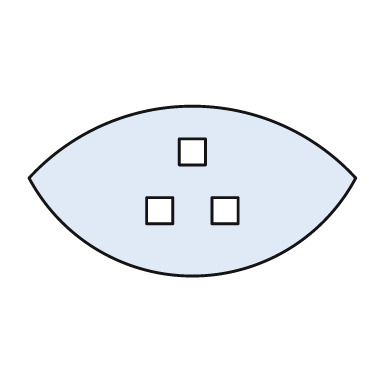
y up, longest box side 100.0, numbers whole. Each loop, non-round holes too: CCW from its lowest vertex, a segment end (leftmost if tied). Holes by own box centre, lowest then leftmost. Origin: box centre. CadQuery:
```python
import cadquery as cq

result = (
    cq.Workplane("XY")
    .moveTo(-50.0, 4.0)
    .threePointArc((0.0, -26.0), (50.0, 4.0))
    .threePointArc((0.0, 26.0), (-50.0, 4.0))
    .close()
    .moveTo(-14.0, -10.0)
    .lineTo(-6.0, -10.0)
    .lineTo(-6.0, -2.0)
    .lineTo(-14.0, -2.0)
    .close()
    .moveTo(6.0, -10.0)
    .lineTo(14.0, -10.0)
    .lineTo(14.0, -2.0)
    .lineTo(6.0, -2.0)
    .close()
    .moveTo(-4.0, 8.0)
    .lineTo(4.0, 8.0)
    .lineTo(4.0, 16.0)
    .lineTo(-4.0, 16.0)
    .close()
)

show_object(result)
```